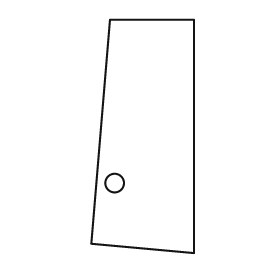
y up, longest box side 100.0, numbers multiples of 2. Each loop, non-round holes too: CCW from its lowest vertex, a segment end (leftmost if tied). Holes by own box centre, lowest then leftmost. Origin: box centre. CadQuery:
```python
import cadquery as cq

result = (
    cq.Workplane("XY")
    .moveTo(22.0, -50.0)
    .lineTo(22.0, 50.0)
    .lineTo(-14.0, 50.0)
    .lineTo(-22.0, -46.0)
    .close()
    .moveTo(-12.0, -20.0)
    .circle(4.0)
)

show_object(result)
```